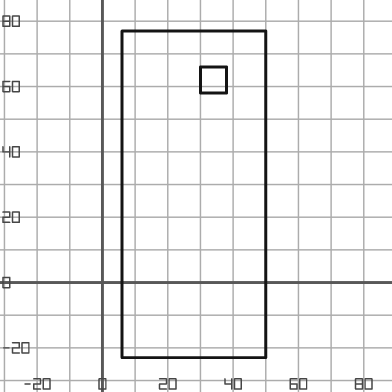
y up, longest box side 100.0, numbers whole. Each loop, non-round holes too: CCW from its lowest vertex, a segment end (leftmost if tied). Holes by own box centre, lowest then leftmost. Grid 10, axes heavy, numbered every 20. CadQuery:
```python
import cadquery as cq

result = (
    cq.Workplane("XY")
    .moveTo(6.0, -23.0)
    .lineTo(50.0, -23.0)
    .lineTo(50.0, 77.0)
    .lineTo(6.0, 77.0)
    .close()
    .moveTo(30.0, 58.0)
    .lineTo(38.0, 58.0)
    .lineTo(38.0, 66.0)
    .lineTo(30.0, 66.0)
    .close()
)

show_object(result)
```